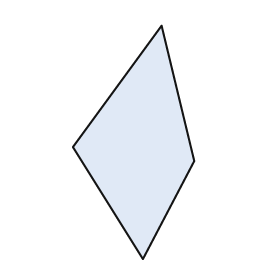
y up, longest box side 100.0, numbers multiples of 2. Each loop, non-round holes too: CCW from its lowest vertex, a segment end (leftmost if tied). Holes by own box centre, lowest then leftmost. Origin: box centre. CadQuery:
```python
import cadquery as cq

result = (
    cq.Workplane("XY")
    .moveTo(4.0, -50.0)
    .lineTo(26.0, -8.0)
    .lineTo(12.0, 50.0)
    .lineTo(-26.0, -2.0)
    .close()
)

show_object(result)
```